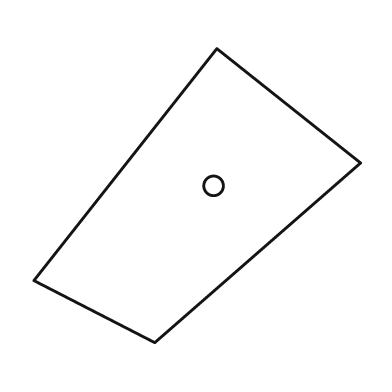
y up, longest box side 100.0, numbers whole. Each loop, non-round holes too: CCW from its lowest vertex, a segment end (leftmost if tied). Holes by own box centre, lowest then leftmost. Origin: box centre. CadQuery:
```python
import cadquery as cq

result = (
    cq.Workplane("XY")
    .moveTo(-13.0, -45.0)
    .lineTo(50.0, 10.0)
    .lineTo(6.0, 45.0)
    .lineTo(-50.0, -26.0)
    .close()
    .moveTo(5.0, 3.0)
    .circle(3.0)
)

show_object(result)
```